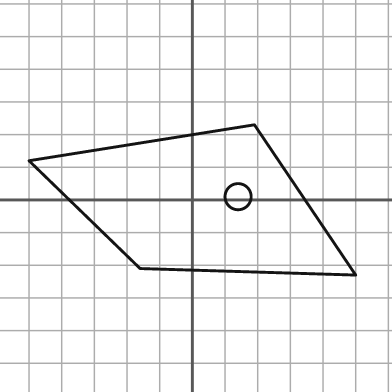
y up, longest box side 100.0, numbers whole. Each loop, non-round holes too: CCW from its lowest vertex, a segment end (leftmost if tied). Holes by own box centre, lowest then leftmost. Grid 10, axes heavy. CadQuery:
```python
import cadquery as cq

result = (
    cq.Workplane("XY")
    .moveTo(50.0, -23.0)
    .lineTo(19.0, 23.0)
    .lineTo(-50.0, 12.0)
    .lineTo(-16.0, -21.0)
    .close()
    .moveTo(14.0, 1.0)
    .circle(4.0)
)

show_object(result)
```